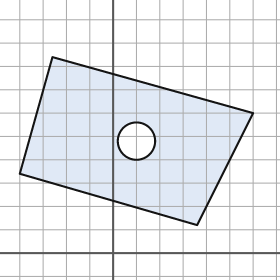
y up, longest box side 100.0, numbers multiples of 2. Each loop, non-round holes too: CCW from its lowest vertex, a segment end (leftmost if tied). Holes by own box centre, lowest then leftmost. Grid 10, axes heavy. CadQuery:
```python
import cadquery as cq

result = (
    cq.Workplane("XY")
    .moveTo(36.0, 12.0)
    .lineTo(60.0, 60.0)
    .lineTo(-26.0, 84.0)
    .lineTo(-40.0, 34.0)
    .close()
    .moveTo(10.0, 48.0)
    .circle(8.0)
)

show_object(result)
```